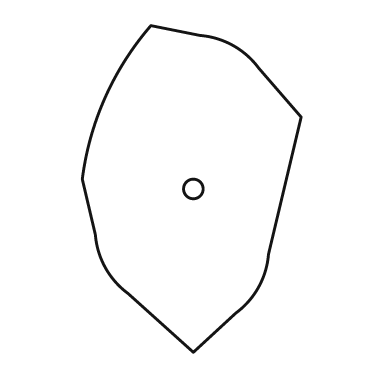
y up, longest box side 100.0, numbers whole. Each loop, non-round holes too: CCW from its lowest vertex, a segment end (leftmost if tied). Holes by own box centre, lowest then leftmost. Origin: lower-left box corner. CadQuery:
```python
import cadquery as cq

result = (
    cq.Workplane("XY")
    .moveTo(34.0, 0.0)
    .lineTo(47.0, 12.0)
    .threePointArc((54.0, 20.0), (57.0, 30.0))
    .lineTo(67.0, 72.0)
    .lineTo(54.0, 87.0)
    .threePointArc((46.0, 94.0), (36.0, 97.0))
    .lineTo(21.0, 100.0)
    .threePointArc((7.0, 78.0), (0.0, 53.0))
    .lineTo(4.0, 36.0)
    .threePointArc((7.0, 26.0), (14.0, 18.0))
    .close()
    .moveTo(34.0, 50.0)
    .circle(3.0)
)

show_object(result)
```